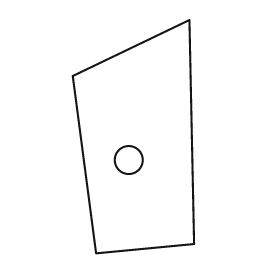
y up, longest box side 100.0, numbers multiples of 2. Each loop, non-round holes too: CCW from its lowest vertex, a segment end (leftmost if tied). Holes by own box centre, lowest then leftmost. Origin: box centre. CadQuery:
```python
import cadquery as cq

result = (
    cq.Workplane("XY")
    .moveTo(-16.0, -50.0)
    .lineTo(26.0, -46.0)
    .lineTo(24.0, 50.0)
    .lineTo(-26.0, 26.0)
    .close()
    .moveTo(-2.0, -10.0)
    .circle(6.0)
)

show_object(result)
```